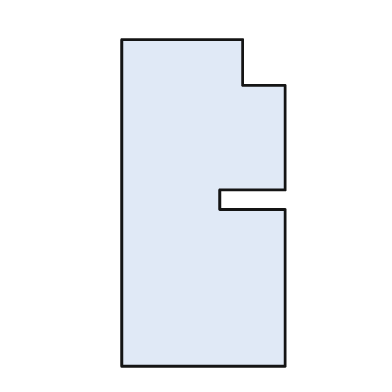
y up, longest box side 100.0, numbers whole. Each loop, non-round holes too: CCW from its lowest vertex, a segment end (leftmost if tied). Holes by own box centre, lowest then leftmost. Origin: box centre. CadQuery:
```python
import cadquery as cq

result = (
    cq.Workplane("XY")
    .moveTo(-25.0, -50.0)
    .lineTo(25.0, -50.0)
    .lineTo(25.0, -2.0)
    .lineTo(5.0, -2.0)
    .lineTo(5.0, 4.0)
    .lineTo(25.0, 4.0)
    .lineTo(25.0, 36.0)
    .lineTo(12.0, 36.0)
    .lineTo(12.0, 50.0)
    .lineTo(-25.0, 50.0)
    .close()
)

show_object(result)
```